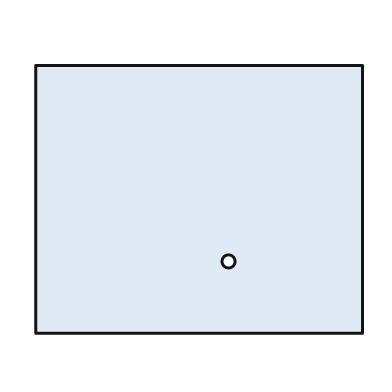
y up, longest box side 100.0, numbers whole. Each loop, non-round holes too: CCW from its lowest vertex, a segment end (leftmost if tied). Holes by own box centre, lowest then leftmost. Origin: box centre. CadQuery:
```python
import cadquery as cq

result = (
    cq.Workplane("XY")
    .moveTo(-50.0, -41.0)
    .lineTo(50.0, -41.0)
    .lineTo(50.0, 41.0)
    .lineTo(-50.0, 41.0)
    .close()
    .moveTo(9.0, -19.0)
    .circle(2.0)
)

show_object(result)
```